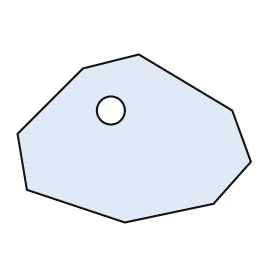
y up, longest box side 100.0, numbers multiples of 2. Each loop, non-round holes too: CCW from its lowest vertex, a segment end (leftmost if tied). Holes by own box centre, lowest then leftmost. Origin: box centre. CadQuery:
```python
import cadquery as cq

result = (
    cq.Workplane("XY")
    .moveTo(-4.0, -36.0)
    .lineTo(34.0, -28.0)
    .lineTo(50.0, -10.0)
    .lineTo(42.0, 12.0)
    .lineTo(2.0, 36.0)
    .lineTo(-22.0, 30.0)
    .lineTo(-50.0, 2.0)
    .lineTo(-46.0, -22.0)
    .close()
    .moveTo(-10.0, 12.0)
    .circle(6.0)
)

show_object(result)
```